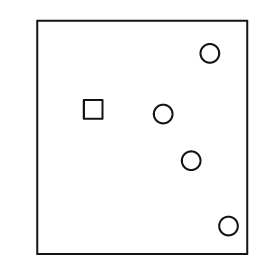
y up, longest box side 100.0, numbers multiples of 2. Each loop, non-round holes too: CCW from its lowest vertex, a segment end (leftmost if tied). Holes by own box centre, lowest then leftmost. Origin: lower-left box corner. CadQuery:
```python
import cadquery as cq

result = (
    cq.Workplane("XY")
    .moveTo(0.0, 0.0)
    .lineTo(90.0, 0.0)
    .lineTo(90.0, 100.0)
    .lineTo(0.0, 100.0)
    .close()
    .moveTo(82.0, 12.0)
    .circle(4.0)
    .moveTo(66.0, 40.0)
    .circle(4.0)
    .moveTo(54.0, 60.0)
    .circle(4.0)
    .moveTo(20.0, 58.0)
    .lineTo(28.0, 58.0)
    .lineTo(28.0, 66.0)
    .lineTo(20.0, 66.0)
    .close()
    .moveTo(74.0, 86.0)
    .circle(4.0)
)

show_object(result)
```